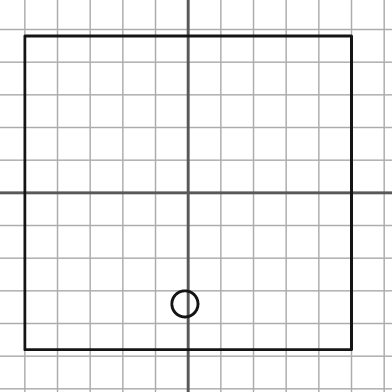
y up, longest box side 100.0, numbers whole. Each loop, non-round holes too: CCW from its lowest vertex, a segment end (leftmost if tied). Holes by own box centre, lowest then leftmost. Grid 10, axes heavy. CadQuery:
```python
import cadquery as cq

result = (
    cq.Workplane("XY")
    .moveTo(-50.0, -48.0)
    .lineTo(50.0, -48.0)
    .lineTo(50.0, 48.0)
    .lineTo(-50.0, 48.0)
    .close()
    .moveTo(-1.0, -34.0)
    .circle(4.0)
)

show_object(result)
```